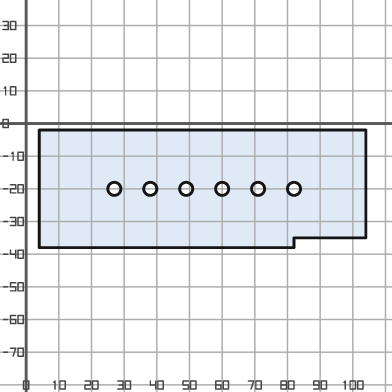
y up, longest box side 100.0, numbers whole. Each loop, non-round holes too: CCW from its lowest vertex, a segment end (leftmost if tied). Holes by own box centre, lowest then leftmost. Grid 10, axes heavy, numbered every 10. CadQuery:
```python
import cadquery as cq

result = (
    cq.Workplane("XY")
    .moveTo(4.0, -38.0)
    .lineTo(82.0, -38.0)
    .lineTo(82.0, -35.0)
    .lineTo(104.0, -35.0)
    .lineTo(104.0, -2.0)
    .lineTo(4.0, -2.0)
    .close()
    .moveTo(27.0, -20.0)
    .circle(2.0)
    .moveTo(38.0, -20.0)
    .circle(2.0)
    .moveTo(49.0, -20.0)
    .circle(2.0)
    .moveTo(60.0, -20.0)
    .circle(2.0)
    .moveTo(71.0, -20.0)
    .circle(2.0)
    .moveTo(82.0, -20.0)
    .circle(2.0)
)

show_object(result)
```